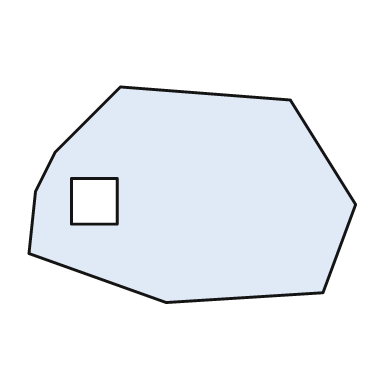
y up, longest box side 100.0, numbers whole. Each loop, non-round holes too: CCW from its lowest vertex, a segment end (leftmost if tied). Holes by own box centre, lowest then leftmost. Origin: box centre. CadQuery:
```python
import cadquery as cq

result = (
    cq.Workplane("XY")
    .moveTo(-8.0, -33.0)
    .lineTo(40.0, -30.0)
    .lineTo(50.0, -3.0)
    .lineTo(30.0, 29.0)
    .lineTo(-22.0, 33.0)
    .lineTo(-42.0, 13.0)
    .lineTo(-48.0, 1.0)
    .lineTo(-50.0, -18.0)
    .close()
    .moveTo(-37.0, -9.0)
    .lineTo(-23.0, -9.0)
    .lineTo(-23.0, 5.0)
    .lineTo(-37.0, 5.0)
    .close()
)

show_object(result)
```